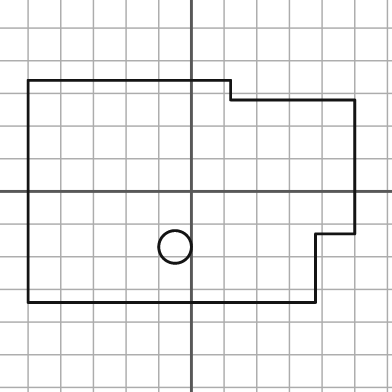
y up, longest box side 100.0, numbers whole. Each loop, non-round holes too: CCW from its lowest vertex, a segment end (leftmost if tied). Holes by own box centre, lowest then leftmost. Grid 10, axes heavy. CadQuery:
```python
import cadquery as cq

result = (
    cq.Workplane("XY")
    .moveTo(-50.0, -34.0)
    .lineTo(38.0, -34.0)
    .lineTo(38.0, -13.0)
    .lineTo(50.0, -13.0)
    .lineTo(50.0, 28.0)
    .lineTo(12.0, 28.0)
    .lineTo(12.0, 34.0)
    .lineTo(-50.0, 34.0)
    .close()
    .moveTo(-5.0, -17.0)
    .circle(5.0)
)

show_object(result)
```